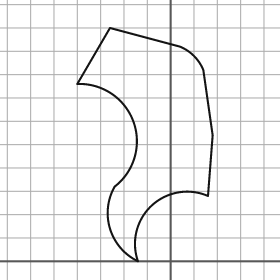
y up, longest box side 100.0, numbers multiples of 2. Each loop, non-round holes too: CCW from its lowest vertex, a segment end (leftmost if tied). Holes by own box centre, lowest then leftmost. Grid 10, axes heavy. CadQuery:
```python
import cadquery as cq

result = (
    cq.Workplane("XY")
    .moveTo(-14.0, 0.0)
    .threePointArc((-8.0, 24.0), (16.0, 28.0))
    .lineTo(18.0, 54.0)
    .lineTo(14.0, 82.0)
    .threePointArc((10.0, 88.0), (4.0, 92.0))
    .lineTo(-26.0, 100.0)
    .lineTo(-40.0, 76.0)
    .threePointArc((-16.0, 60.0), (-24.0, 32.0))
    .threePointArc((-26.0, 14.0), (-14.0, 0.0))
    .close()
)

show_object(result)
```